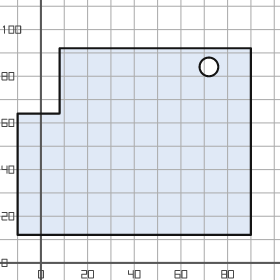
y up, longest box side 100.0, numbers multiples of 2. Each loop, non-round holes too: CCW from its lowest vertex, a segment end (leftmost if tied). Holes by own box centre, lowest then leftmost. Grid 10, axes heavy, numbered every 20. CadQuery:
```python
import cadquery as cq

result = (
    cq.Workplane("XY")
    .moveTo(-10.0, 12.0)
    .lineTo(90.0, 12.0)
    .lineTo(90.0, 92.0)
    .lineTo(8.0, 92.0)
    .lineTo(8.0, 64.0)
    .lineTo(-10.0, 64.0)
    .close()
    .moveTo(72.0, 84.0)
    .circle(4.0)
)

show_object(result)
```